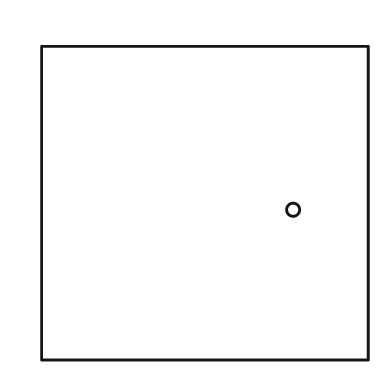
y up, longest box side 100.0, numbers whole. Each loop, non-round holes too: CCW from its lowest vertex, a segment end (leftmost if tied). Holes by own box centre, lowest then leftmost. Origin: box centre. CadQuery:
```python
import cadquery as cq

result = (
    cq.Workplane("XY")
    .moveTo(-50.0, -48.0)
    .lineTo(50.0, -48.0)
    .lineTo(50.0, 48.0)
    .lineTo(-50.0, 48.0)
    .close()
    .moveTo(27.0, -2.0)
    .circle(2.0)
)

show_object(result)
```